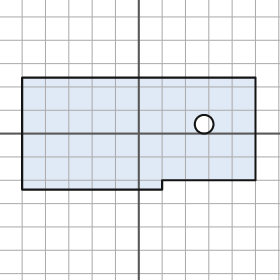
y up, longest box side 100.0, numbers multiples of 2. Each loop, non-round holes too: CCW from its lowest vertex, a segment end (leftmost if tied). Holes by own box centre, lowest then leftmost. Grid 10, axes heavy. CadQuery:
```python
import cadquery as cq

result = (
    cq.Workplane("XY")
    .moveTo(-50.0, -24.0)
    .lineTo(10.0, -24.0)
    .lineTo(10.0, -20.0)
    .lineTo(50.0, -20.0)
    .lineTo(50.0, 24.0)
    .lineTo(-50.0, 24.0)
    .close()
    .moveTo(28.0, 4.0)
    .circle(4.0)
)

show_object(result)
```